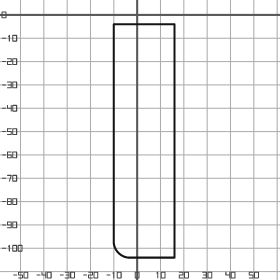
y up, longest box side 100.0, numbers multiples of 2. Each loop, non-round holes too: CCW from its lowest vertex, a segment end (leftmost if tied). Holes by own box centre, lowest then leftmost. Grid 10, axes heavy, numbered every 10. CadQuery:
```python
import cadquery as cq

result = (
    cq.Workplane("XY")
    .moveTo(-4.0, -104.0)
    .lineTo(16.0, -104.0)
    .lineTo(16.0, -4.0)
    .lineTo(-10.0, -4.0)
    .lineTo(-10.0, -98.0)
    .threePointArc((-8.0, -102.0), (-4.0, -104.0))
    .close()
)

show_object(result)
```